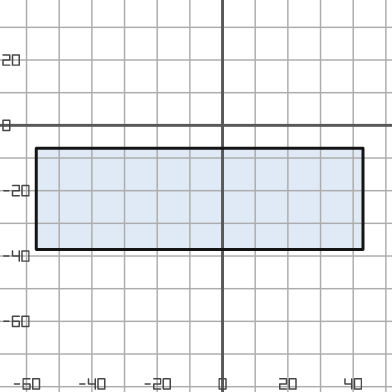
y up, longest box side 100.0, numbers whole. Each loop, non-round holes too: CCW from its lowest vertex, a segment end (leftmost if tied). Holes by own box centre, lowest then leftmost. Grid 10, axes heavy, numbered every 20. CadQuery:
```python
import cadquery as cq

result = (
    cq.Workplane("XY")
    .moveTo(-57.0, -38.0)
    .lineTo(43.0, -38.0)
    .lineTo(43.0, -7.0)
    .lineTo(-57.0, -7.0)
    .close()
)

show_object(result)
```